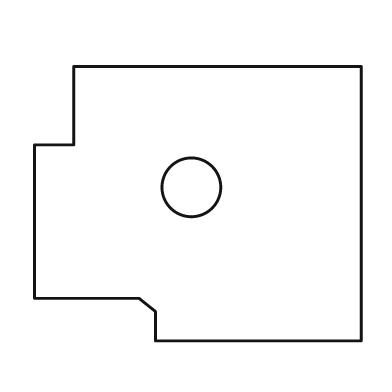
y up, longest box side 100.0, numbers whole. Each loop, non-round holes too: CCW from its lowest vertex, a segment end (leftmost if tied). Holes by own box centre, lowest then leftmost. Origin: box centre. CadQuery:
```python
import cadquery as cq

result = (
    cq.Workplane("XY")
    .moveTo(-13.0, -42.0)
    .lineTo(50.0, -42.0)
    .lineTo(50.0, 42.0)
    .lineTo(-38.0, 42.0)
    .lineTo(-38.0, 18.0)
    .lineTo(-50.0, 18.0)
    .lineTo(-50.0, -29.0)
    .lineTo(-18.0, -29.0)
    .lineTo(-13.0, -33.0)
    .close()
    .moveTo(-2.0, 5.0)
    .circle(9.0)
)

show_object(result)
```